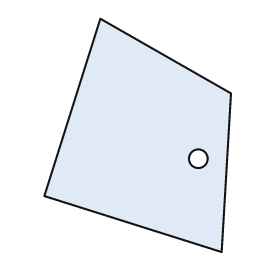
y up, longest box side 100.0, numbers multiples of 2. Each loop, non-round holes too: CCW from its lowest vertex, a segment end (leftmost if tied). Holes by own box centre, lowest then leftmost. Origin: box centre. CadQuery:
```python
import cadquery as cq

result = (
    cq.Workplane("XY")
    .moveTo(36.0, -50.0)
    .lineTo(40.0, 18.0)
    .lineTo(-16.0, 50.0)
    .lineTo(-40.0, -26.0)
    .close()
    .moveTo(26.0, -10.0)
    .circle(4.0)
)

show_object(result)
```